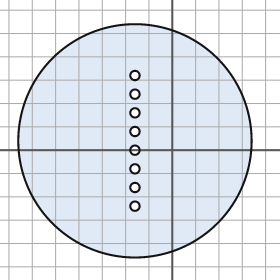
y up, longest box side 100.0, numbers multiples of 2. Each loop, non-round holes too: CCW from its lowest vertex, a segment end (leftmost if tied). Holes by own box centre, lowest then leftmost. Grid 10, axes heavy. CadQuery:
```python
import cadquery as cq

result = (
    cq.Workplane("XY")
    .moveTo(-16.0, 4.0)
    .circle(50.0)
    .moveTo(-16.0, -24.0)
    .circle(2.0)
    .moveTo(-16.0, -16.0)
    .circle(2.0)
    .moveTo(-16.0, -8.0)
    .circle(2.0)
    .moveTo(-16.0, 0.0)
    .circle(2.0)
    .moveTo(-16.0, 8.0)
    .circle(2.0)
    .moveTo(-16.0, 16.0)
    .circle(2.0)
    .moveTo(-16.0, 24.0)
    .circle(2.0)
    .moveTo(-16.0, 32.0)
    .circle(2.0)
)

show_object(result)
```